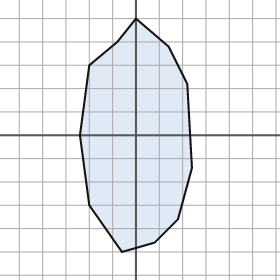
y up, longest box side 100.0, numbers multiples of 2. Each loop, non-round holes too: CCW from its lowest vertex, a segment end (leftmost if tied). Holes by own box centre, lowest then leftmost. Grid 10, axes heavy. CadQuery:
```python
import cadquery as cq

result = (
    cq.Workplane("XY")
    .moveTo(-6.0, -50.0)
    .lineTo(8.0, -46.0)
    .lineTo(18.0, -36.0)
    .lineTo(24.0, -14.0)
    .lineTo(22.0, 22.0)
    .lineTo(14.0, 38.0)
    .lineTo(0.0, 50.0)
    .lineTo(-8.0, 40.0)
    .lineTo(-20.0, 30.0)
    .lineTo(-24.0, 0.0)
    .lineTo(-20.0, -30.0)
    .close()
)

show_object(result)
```